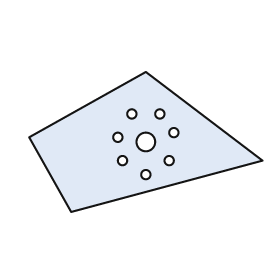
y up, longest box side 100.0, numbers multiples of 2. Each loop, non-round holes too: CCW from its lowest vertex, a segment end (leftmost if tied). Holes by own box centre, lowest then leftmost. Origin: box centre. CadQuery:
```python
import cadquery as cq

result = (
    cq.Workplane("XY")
    .moveTo(-32.0, -30.0)
    .lineTo(50.0, -8.0)
    .lineTo(0.0, 30.0)
    .lineTo(-50.0, 2.0)
    .close()
    .moveTo(0.0, -14.0)
    .circle(2.0)
    .moveTo(-10.0, -8.0)
    .circle(2.0)
    .moveTo(10.0, -8.0)
    .circle(2.0)
    .moveTo(0.0, 0.0)
    .circle(4.0)
    .moveTo(-12.0, 2.0)
    .circle(2.0)
    .moveTo(12.0, 4.0)
    .circle(2.0)
    .moveTo(-6.0, 12.0)
    .circle(2.0)
    .moveTo(6.0, 12.0)
    .circle(2.0)
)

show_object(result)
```